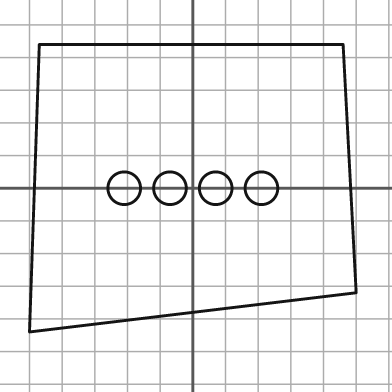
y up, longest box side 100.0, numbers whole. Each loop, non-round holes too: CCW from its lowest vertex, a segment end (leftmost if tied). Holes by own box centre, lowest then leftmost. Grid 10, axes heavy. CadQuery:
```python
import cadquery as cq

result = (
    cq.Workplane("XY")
    .moveTo(-50.0, -44.0)
    .lineTo(50.0, -32.0)
    .lineTo(46.0, 44.0)
    .lineTo(-47.0, 44.0)
    .close()
    .moveTo(-21.0, 0.0)
    .circle(5.0)
    .moveTo(-7.0, 0.0)
    .circle(5.0)
    .moveTo(7.0, 0.0)
    .circle(5.0)
    .moveTo(21.0, 0.0)
    .circle(5.0)
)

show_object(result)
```